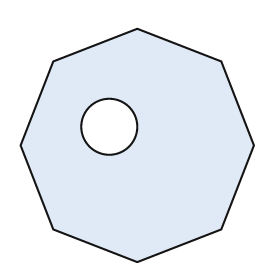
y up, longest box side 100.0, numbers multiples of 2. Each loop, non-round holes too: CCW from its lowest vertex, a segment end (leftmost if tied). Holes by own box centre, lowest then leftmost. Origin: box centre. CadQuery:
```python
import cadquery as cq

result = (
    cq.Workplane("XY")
    .moveTo(0.0, -50.0)
    .lineTo(36.0, -36.0)
    .lineTo(50.0, 0.0)
    .lineTo(36.0, 36.0)
    .lineTo(0.0, 50.0)
    .lineTo(-36.0, 36.0)
    .lineTo(-50.0, 0.0)
    .lineTo(-36.0, -36.0)
    .close()
    .moveTo(-12.0, 8.0)
    .circle(12.0)
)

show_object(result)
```